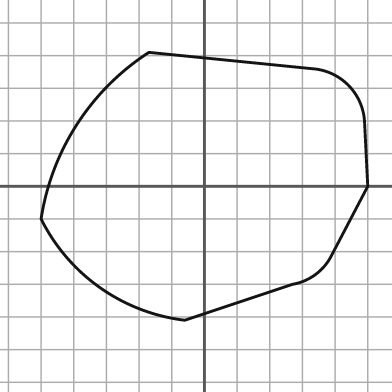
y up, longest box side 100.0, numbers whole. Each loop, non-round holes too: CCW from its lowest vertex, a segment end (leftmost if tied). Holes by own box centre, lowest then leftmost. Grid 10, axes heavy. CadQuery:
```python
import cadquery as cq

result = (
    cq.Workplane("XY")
    .moveTo(-6.0, -41.0)
    .lineTo(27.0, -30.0)
    .threePointArc((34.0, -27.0), (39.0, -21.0))
    .lineTo(50.0, 0.0)
    .lineTo(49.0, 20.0)
    .threePointArc((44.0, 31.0), (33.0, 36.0))
    .lineTo(-17.0, 41.0)
    .threePointArc((-39.0, 19.0), (-50.0, -10.0))
    .threePointArc((-32.0, -31.0), (-6.0, -41.0))
    .close()
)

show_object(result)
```